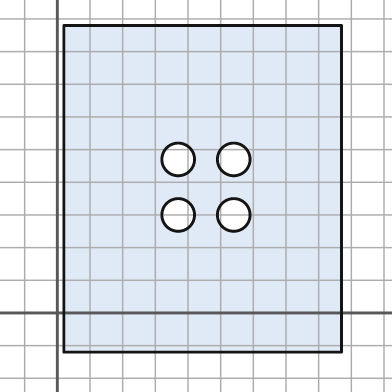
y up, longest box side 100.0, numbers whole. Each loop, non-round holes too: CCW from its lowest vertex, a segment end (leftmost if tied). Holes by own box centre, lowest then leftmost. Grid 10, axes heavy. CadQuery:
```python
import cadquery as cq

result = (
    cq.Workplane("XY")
    .moveTo(2.0, -12.0)
    .lineTo(87.0, -12.0)
    .lineTo(87.0, 88.0)
    .lineTo(2.0, 88.0)
    .close()
    .moveTo(37.0, 30.0)
    .circle(5.0)
    .moveTo(54.0, 30.0)
    .circle(5.0)
    .moveTo(37.0, 47.0)
    .circle(5.0)
    .moveTo(54.0, 47.0)
    .circle(5.0)
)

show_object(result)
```